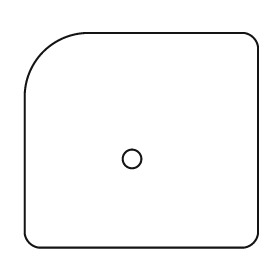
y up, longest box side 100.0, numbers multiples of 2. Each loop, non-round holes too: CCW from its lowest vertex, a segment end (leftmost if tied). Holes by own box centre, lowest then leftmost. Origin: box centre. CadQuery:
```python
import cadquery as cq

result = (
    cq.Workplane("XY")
    .moveTo(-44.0, -46.0)
    .lineTo(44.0, -46.0)
    .threePointArc((48.0, -44.0), (50.0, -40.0))
    .lineTo(50.0, 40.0)
    .threePointArc((48.0, 44.0), (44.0, 46.0))
    .lineTo(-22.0, 46.0)
    .threePointArc((-42.0, 38.0), (-50.0, 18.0))
    .lineTo(-50.0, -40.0)
    .threePointArc((-48.0, -44.0), (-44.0, -46.0))
    .close()
    .moveTo(-4.0, -8.0)
    .circle(4.0)
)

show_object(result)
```